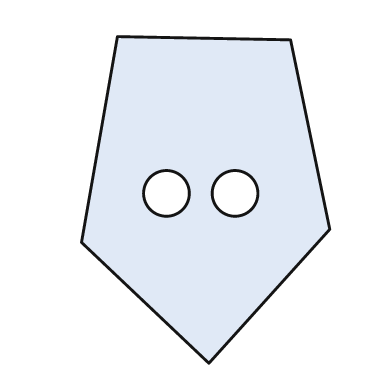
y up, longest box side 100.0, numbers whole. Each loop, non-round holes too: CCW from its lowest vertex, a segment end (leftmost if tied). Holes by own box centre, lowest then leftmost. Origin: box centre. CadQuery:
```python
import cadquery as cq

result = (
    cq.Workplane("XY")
    .moveTo(1.0, -50.0)
    .lineTo(38.0, -9.0)
    .lineTo(26.0, 49.0)
    .lineTo(-27.0, 50.0)
    .lineTo(-38.0, -13.0)
    .close()
    .moveTo(-12.0, 2.0)
    .circle(7.0)
    .moveTo(9.0, 2.0)
    .circle(7.0)
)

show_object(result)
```